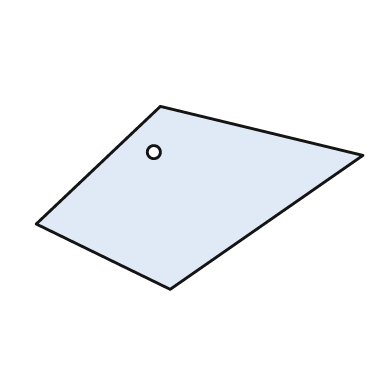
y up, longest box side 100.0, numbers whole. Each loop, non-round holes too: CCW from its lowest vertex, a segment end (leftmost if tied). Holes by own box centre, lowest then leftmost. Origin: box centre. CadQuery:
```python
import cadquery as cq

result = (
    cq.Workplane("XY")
    .moveTo(-9.0, -28.0)
    .lineTo(50.0, 13.0)
    .lineTo(-12.0, 28.0)
    .lineTo(-50.0, -8.0)
    .close()
    .moveTo(-14.0, 14.0)
    .circle(2.0)
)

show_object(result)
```